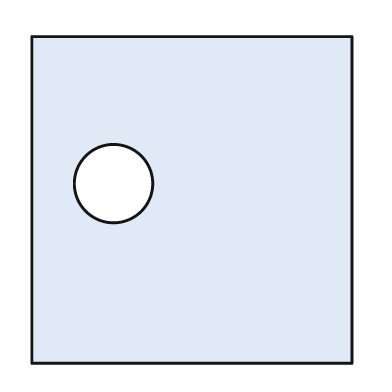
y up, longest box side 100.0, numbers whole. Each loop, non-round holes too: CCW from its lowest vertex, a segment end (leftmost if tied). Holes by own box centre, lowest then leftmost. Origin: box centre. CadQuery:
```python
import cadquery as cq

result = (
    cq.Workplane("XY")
    .moveTo(-49.0, -50.0)
    .lineTo(49.0, -50.0)
    .lineTo(49.0, 50.0)
    .lineTo(-49.0, 50.0)
    .close()
    .moveTo(-24.0, 5.0)
    .circle(12.0)
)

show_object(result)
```